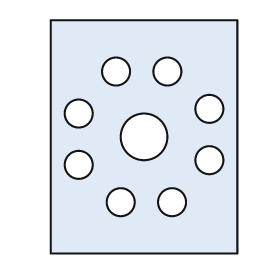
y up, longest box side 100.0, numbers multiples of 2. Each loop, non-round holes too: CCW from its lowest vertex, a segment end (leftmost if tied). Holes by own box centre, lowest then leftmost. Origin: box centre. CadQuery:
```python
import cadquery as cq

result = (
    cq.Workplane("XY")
    .moveTo(-40.0, -50.0)
    .lineTo(40.0, -50.0)
    .lineTo(40.0, 50.0)
    .lineTo(-40.0, 50.0)
    .close()
    .moveTo(-10.0, -28.0)
    .circle(6.0)
    .moveTo(12.0, -28.0)
    .circle(6.0)
    .moveTo(-28.0, -12.0)
    .circle(6.0)
    .moveTo(28.0, -10.0)
    .circle(6.0)
    .moveTo(0.0, 0.0)
    .circle(10.0)
    .moveTo(-28.0, 10.0)
    .circle(6.0)
    .moveTo(28.0, 12.0)
    .circle(6.0)
    .moveTo(-12.0, 28.0)
    .circle(6.0)
    .moveTo(10.0, 28.0)
    .circle(6.0)
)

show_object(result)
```